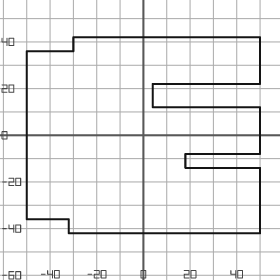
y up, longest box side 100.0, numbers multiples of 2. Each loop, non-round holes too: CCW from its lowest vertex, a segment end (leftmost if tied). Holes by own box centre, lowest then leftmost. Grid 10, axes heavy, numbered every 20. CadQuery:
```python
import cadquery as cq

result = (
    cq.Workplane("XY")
    .moveTo(-32.0, -42.0)
    .lineTo(50.0, -42.0)
    .lineTo(50.0, -14.0)
    .lineTo(18.0, -14.0)
    .lineTo(18.0, -8.0)
    .lineTo(50.0, -8.0)
    .lineTo(50.0, 12.0)
    .lineTo(4.0, 12.0)
    .lineTo(4.0, 22.0)
    .lineTo(50.0, 22.0)
    .lineTo(50.0, 42.0)
    .lineTo(-30.0, 42.0)
    .lineTo(-30.0, 36.0)
    .lineTo(-50.0, 36.0)
    .lineTo(-50.0, -36.0)
    .lineTo(-32.0, -36.0)
    .close()
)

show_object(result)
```